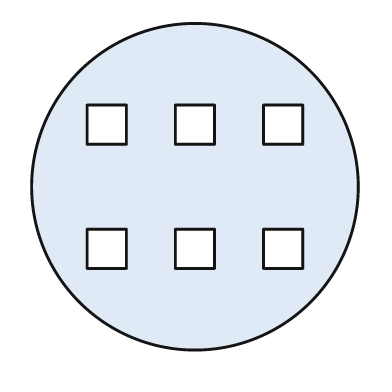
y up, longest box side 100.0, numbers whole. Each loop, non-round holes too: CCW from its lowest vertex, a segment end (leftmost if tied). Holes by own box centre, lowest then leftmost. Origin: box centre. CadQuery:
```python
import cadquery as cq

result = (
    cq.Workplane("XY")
    .moveTo(0.0, 0.0)
    .circle(50.0)
    .moveTo(-33.0, -25.0)
    .lineTo(-21.0, -25.0)
    .lineTo(-21.0, -13.0)
    .lineTo(-33.0, -13.0)
    .close()
    .moveTo(-6.0, -25.0)
    .lineTo(6.0, -25.0)
    .lineTo(6.0, -13.0)
    .lineTo(-6.0, -13.0)
    .close()
    .moveTo(21.0, -25.0)
    .lineTo(33.0, -25.0)
    .lineTo(33.0, -13.0)
    .lineTo(21.0, -13.0)
    .close()
    .moveTo(-33.0, 13.0)
    .lineTo(-21.0, 13.0)
    .lineTo(-21.0, 25.0)
    .lineTo(-33.0, 25.0)
    .close()
    .moveTo(-6.0, 13.0)
    .lineTo(6.0, 13.0)
    .lineTo(6.0, 25.0)
    .lineTo(-6.0, 25.0)
    .close()
    .moveTo(21.0, 13.0)
    .lineTo(33.0, 13.0)
    .lineTo(33.0, 25.0)
    .lineTo(21.0, 25.0)
    .close()
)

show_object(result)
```